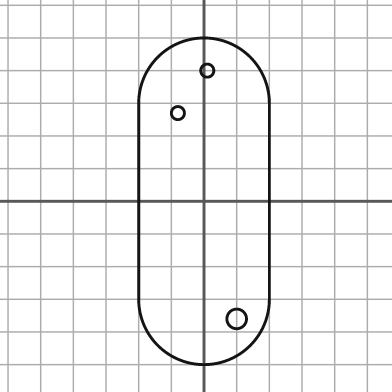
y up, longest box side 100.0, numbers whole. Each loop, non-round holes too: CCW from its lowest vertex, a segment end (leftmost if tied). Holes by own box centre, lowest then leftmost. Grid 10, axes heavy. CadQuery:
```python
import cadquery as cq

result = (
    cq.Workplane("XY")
    .moveTo(-20.0, -30.0)
    .threePointArc((0.0, -50.0), (20.0, -30.0))
    .lineTo(20.0, 30.0)
    .threePointArc((0.0, 50.0), (-20.0, 30.0))
    .close()
    .moveTo(10.0, -36.0)
    .circle(3.0)
    .moveTo(-8.0, 27.0)
    .circle(2.0)
    .moveTo(1.0, 40.0)
    .circle(2.0)
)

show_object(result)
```